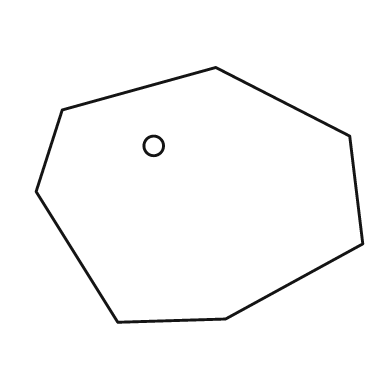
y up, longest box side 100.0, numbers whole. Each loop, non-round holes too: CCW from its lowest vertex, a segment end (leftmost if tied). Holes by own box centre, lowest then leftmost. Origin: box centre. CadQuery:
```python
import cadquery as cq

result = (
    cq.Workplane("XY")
    .moveTo(-25.0, -39.0)
    .lineTo(8.0, -38.0)
    .lineTo(50.0, -15.0)
    .lineTo(46.0, 18.0)
    .lineTo(5.0, 39.0)
    .lineTo(-42.0, 26.0)
    .lineTo(-50.0, 1.0)
    .close()
    .moveTo(-14.0, 15.0)
    .circle(3.0)
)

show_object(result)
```